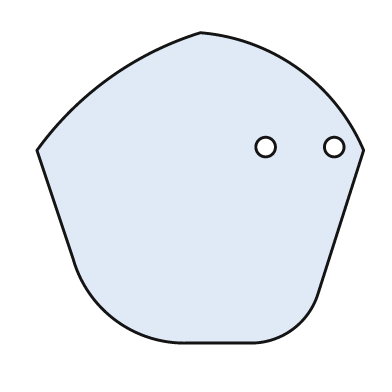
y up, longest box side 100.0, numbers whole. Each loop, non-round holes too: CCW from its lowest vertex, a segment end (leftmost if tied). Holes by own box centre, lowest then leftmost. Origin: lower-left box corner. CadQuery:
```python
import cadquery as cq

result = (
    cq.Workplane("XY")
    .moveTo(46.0, 0.0)
    .lineTo(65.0, 0.0)
    .threePointArc((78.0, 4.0), (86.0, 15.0))
    .lineTo(100.0, 59.0)
    .threePointArc((80.0, 84.0), (50.0, 95.0))
    .threePointArc((22.0, 81.0), (0.0, 59.0))
    .lineTo(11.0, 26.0)
    .threePointArc((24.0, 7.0), (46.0, 0.0))
    .close()
    .moveTo(70.0, 60.0)
    .circle(3.0)
    .moveTo(91.0, 60.0)
    .circle(3.0)
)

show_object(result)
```